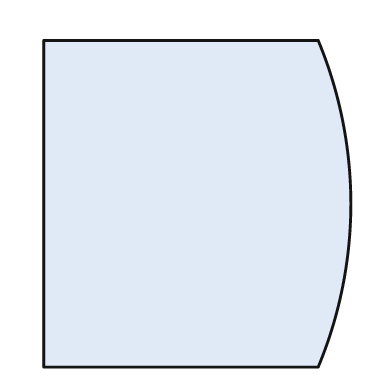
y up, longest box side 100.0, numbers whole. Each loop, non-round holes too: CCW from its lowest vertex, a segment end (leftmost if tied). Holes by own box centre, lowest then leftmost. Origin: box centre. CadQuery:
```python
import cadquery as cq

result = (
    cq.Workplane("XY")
    .moveTo(-47.0, -50.0)
    .lineTo(37.0, -50.0)
    .threePointArc((47.0, 0.0), (37.0, 50.0))
    .lineTo(-47.0, 50.0)
    .close()
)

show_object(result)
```